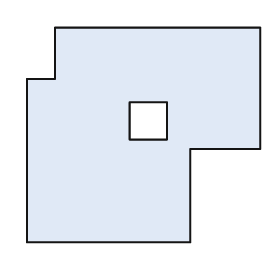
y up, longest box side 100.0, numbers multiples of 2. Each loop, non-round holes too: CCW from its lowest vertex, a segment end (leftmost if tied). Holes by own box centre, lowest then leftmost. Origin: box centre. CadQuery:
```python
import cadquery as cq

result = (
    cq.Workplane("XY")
    .moveTo(-50.0, -46.0)
    .lineTo(20.0, -46.0)
    .lineTo(20.0, -6.0)
    .lineTo(50.0, -6.0)
    .lineTo(50.0, 46.0)
    .lineTo(-38.0, 46.0)
    .lineTo(-38.0, 24.0)
    .lineTo(-50.0, 24.0)
    .close()
    .moveTo(-6.0, -2.0)
    .lineTo(10.0, -2.0)
    .lineTo(10.0, 14.0)
    .lineTo(-6.0, 14.0)
    .close()
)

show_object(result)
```